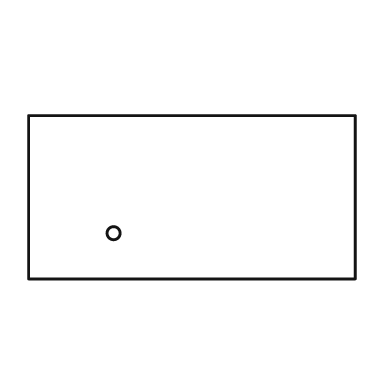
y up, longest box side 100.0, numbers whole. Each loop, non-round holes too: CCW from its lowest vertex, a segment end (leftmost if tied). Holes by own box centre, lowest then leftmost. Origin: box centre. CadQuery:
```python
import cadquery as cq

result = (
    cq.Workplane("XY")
    .moveTo(-50.0, -25.0)
    .lineTo(50.0, -25.0)
    .lineTo(50.0, 25.0)
    .lineTo(-50.0, 25.0)
    .close()
    .moveTo(-24.0, -11.0)
    .circle(2.0)
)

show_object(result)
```